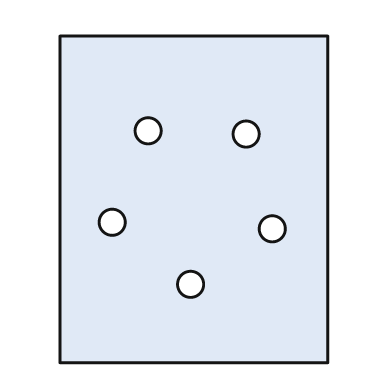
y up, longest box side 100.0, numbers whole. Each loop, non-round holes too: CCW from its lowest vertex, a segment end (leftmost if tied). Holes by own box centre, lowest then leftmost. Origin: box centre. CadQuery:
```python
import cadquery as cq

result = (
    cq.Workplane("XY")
    .moveTo(-41.0, -50.0)
    .lineTo(41.0, -50.0)
    .lineTo(41.0, 50.0)
    .lineTo(-41.0, 50.0)
    .close()
    .moveTo(-1.0, -26.0)
    .circle(4.0)
    .moveTo(24.0, -9.0)
    .circle(4.0)
    .moveTo(-25.0, -7.0)
    .circle(4.0)
    .moveTo(16.0, 20.0)
    .circle(4.0)
    .moveTo(-14.0, 21.0)
    .circle(4.0)
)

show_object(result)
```